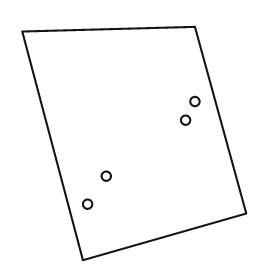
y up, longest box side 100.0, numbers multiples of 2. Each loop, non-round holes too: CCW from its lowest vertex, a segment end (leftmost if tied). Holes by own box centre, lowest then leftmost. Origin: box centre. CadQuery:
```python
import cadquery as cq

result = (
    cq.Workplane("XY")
    .moveTo(-22.0, -50.0)
    .lineTo(48.0, -30.0)
    .lineTo(26.0, 50.0)
    .lineTo(-48.0, 48.0)
    .close()
    .moveTo(-20.0, -26.0)
    .circle(2.0)
    .moveTo(-12.0, -14.0)
    .circle(2.0)
    .moveTo(22.0, 10.0)
    .circle(2.0)
    .moveTo(26.0, 18.0)
    .circle(2.0)
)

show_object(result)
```